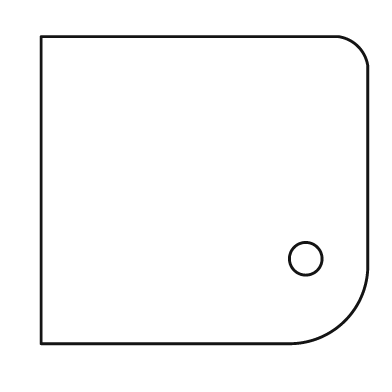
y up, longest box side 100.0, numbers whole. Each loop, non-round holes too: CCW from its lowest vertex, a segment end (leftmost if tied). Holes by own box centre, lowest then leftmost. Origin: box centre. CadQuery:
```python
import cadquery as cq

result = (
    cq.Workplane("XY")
    .moveTo(-50.0, -47.0)
    .lineTo(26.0, -47.0)
    .threePointArc((43.0, -40.0), (50.0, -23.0))
    .lineTo(50.0, 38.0)
    .threePointArc((47.0, 44.0), (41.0, 47.0))
    .lineTo(-50.0, 47.0)
    .close()
    .moveTo(31.0, -21.0)
    .circle(5.0)
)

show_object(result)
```